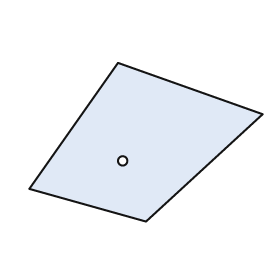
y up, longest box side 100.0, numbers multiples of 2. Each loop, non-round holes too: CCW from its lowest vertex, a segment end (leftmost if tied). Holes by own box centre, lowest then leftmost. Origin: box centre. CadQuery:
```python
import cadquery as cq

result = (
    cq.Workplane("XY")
    .moveTo(0.0, -34.0)
    .lineTo(50.0, 12.0)
    .lineTo(-12.0, 34.0)
    .lineTo(-50.0, -20.0)
    .close()
    .moveTo(-10.0, -8.0)
    .circle(2.0)
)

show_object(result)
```